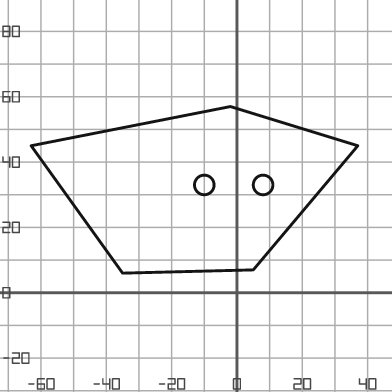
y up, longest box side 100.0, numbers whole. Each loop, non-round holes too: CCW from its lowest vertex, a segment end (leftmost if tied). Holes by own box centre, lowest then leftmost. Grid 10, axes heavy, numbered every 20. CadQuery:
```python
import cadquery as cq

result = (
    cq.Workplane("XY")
    .moveTo(-35.0, 6.0)
    .lineTo(5.0, 7.0)
    .lineTo(37.0, 45.0)
    .lineTo(-2.0, 57.0)
    .lineTo(-63.0, 45.0)
    .close()
    .moveTo(-10.0, 33.0)
    .circle(3.0)
    .moveTo(8.0, 33.0)
    .circle(3.0)
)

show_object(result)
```